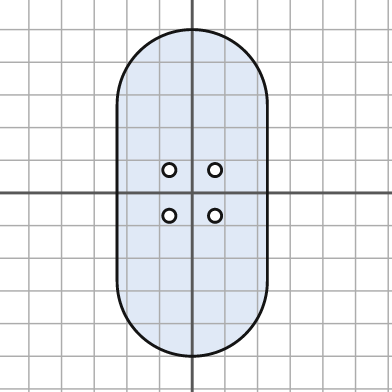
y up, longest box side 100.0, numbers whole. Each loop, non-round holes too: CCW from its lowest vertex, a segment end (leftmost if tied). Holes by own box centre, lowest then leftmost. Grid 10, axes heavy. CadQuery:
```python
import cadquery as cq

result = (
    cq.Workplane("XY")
    .moveTo(-23.0, -27.0)
    .threePointArc((0.0, -50.0), (23.0, -27.0))
    .lineTo(23.0, 27.0)
    .threePointArc((0.0, 50.0), (-23.0, 27.0))
    .close()
    .moveTo(-7.0, -7.0)
    .circle(2.0)
    .moveTo(7.0, -7.0)
    .circle(2.0)
    .moveTo(-7.0, 7.0)
    .circle(2.0)
    .moveTo(7.0, 7.0)
    .circle(2.0)
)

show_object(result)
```